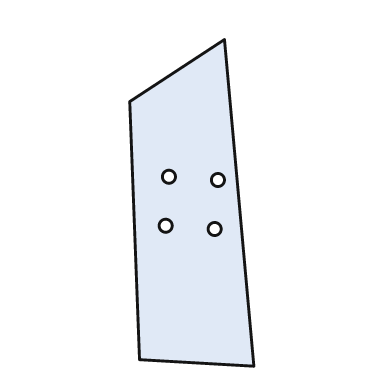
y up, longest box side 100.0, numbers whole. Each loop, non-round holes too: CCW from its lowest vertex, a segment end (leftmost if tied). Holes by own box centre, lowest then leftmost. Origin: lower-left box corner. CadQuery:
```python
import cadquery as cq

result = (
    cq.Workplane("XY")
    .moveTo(38.0, 0.0)
    .lineTo(29.0, 100.0)
    .lineTo(0.0, 81.0)
    .lineTo(3.0, 2.0)
    .close()
    .moveTo(26.0, 42.0)
    .circle(2.0)
    .moveTo(11.0, 43.0)
    .circle(2.0)
    .moveTo(27.0, 57.0)
    .circle(2.0)
    .moveTo(12.0, 58.0)
    .circle(2.0)
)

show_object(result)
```